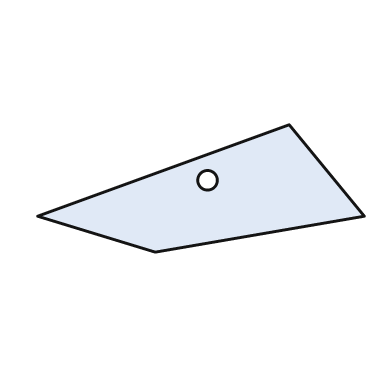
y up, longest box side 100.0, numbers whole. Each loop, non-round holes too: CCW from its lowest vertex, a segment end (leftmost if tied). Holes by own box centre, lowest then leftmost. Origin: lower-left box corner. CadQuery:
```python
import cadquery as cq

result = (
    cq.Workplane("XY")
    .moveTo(36.0, 0.0)
    .lineTo(100.0, 11.0)
    .lineTo(77.0, 39.0)
    .lineTo(0.0, 11.0)
    .close()
    .moveTo(52.0, 22.0)
    .circle(3.0)
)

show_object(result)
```